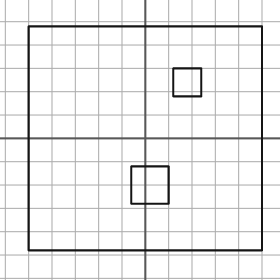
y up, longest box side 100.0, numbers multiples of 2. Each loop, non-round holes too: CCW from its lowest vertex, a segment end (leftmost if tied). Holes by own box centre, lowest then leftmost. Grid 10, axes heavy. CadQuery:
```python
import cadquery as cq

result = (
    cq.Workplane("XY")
    .moveTo(-50.0, -48.0)
    .lineTo(50.0, -48.0)
    .lineTo(50.0, 48.0)
    .lineTo(-50.0, 48.0)
    .close()
    .moveTo(-6.0, -28.0)
    .lineTo(10.0, -28.0)
    .lineTo(10.0, -12.0)
    .lineTo(-6.0, -12.0)
    .close()
    .moveTo(12.0, 18.0)
    .lineTo(24.0, 18.0)
    .lineTo(24.0, 30.0)
    .lineTo(12.0, 30.0)
    .close()
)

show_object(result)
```